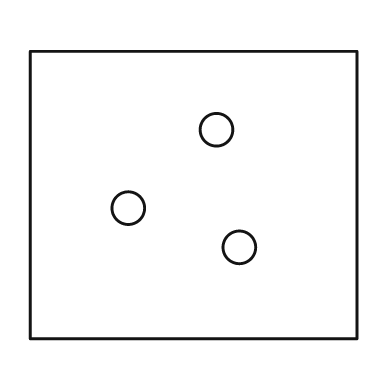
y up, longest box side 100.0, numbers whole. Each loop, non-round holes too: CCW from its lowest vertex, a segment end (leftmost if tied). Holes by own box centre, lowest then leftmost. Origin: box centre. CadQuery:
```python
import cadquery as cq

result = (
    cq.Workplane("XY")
    .moveTo(-50.0, -44.0)
    .lineTo(50.0, -44.0)
    .lineTo(50.0, 44.0)
    .lineTo(-50.0, 44.0)
    .close()
    .moveTo(14.0, -16.0)
    .circle(5.0)
    .moveTo(-20.0, -4.0)
    .circle(5.0)
    .moveTo(7.0, 20.0)
    .circle(5.0)
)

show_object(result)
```